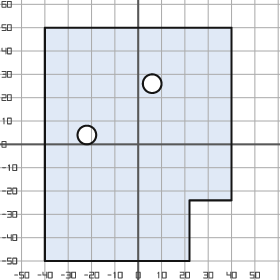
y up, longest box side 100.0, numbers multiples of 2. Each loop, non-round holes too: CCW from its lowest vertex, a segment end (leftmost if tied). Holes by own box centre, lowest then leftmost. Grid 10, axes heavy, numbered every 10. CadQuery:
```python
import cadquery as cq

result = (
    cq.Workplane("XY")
    .moveTo(-40.0, -50.0)
    .lineTo(22.0, -50.0)
    .lineTo(22.0, -24.0)
    .lineTo(40.0, -24.0)
    .lineTo(40.0, 50.0)
    .lineTo(-40.0, 50.0)
    .close()
    .moveTo(-22.0, 4.0)
    .circle(4.0)
    .moveTo(6.0, 26.0)
    .circle(4.0)
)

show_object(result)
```